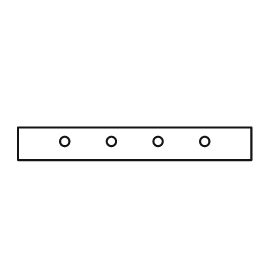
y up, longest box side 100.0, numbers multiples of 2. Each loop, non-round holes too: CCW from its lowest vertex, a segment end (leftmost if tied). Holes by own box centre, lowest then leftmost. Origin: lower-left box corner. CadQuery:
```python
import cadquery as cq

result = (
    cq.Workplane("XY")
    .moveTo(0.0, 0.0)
    .lineTo(100.0, 0.0)
    .lineTo(100.0, 14.0)
    .lineTo(0.0, 14.0)
    .close()
    .moveTo(20.0, 8.0)
    .circle(2.0)
    .moveTo(40.0, 8.0)
    .circle(2.0)
    .moveTo(60.0, 8.0)
    .circle(2.0)
    .moveTo(80.0, 8.0)
    .circle(2.0)
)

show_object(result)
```